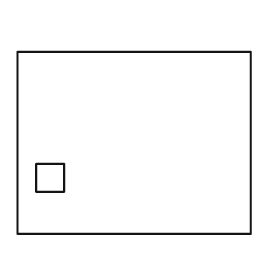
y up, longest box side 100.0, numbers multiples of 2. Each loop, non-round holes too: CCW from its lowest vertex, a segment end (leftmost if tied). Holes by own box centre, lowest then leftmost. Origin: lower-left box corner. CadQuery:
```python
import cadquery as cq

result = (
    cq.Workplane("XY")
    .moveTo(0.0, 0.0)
    .lineTo(100.0, 0.0)
    .lineTo(100.0, 78.0)
    .lineTo(0.0, 78.0)
    .close()
    .moveTo(8.0, 18.0)
    .lineTo(20.0, 18.0)
    .lineTo(20.0, 30.0)
    .lineTo(8.0, 30.0)
    .close()
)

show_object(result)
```